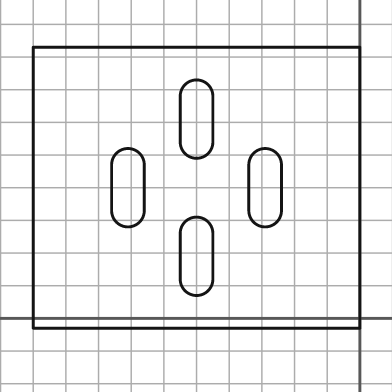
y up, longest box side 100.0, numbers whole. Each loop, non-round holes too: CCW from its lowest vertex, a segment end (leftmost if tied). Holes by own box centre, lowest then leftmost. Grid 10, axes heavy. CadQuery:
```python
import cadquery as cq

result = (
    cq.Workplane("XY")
    .moveTo(-100.0, -3.0)
    .lineTo(0.0, -3.0)
    .lineTo(0.0, 83.0)
    .lineTo(-100.0, 83.0)
    .close()
    .moveTo(-55.0, 12.0)
    .threePointArc((-50.0, 7.0), (-45.0, 12.0))
    .lineTo(-45.0, 26.0)
    .threePointArc((-50.0, 31.0), (-55.0, 26.0))
    .close()
    .moveTo(-76.0, 33.0)
    .threePointArc((-71.0, 28.0), (-66.0, 33.0))
    .lineTo(-66.0, 47.0)
    .threePointArc((-71.0, 52.0), (-76.0, 47.0))
    .close()
    .moveTo(-34.0, 33.0)
    .threePointArc((-29.0, 28.0), (-24.0, 33.0))
    .lineTo(-24.0, 47.0)
    .threePointArc((-29.0, 52.0), (-34.0, 47.0))
    .close()
    .moveTo(-55.0, 54.0)
    .threePointArc((-50.0, 49.0), (-45.0, 54.0))
    .lineTo(-45.0, 68.0)
    .threePointArc((-50.0, 73.0), (-55.0, 68.0))
    .close()
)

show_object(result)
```